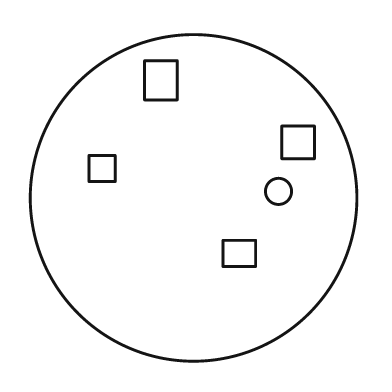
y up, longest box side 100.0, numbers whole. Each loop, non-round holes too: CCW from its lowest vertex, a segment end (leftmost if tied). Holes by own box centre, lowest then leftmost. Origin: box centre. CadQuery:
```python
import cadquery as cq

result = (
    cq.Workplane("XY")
    .moveTo(0.0, 0.0)
    .circle(50.0)
    .moveTo(9.0, -21.0)
    .lineTo(19.0, -21.0)
    .lineTo(19.0, -13.0)
    .lineTo(9.0, -13.0)
    .close()
    .moveTo(26.0, 2.0)
    .circle(4.0)
    .moveTo(-32.0, 5.0)
    .lineTo(-24.0, 5.0)
    .lineTo(-24.0, 13.0)
    .lineTo(-32.0, 13.0)
    .close()
    .moveTo(27.0, 12.0)
    .lineTo(37.0, 12.0)
    .lineTo(37.0, 22.0)
    .lineTo(27.0, 22.0)
    .close()
    .moveTo(-15.0, 30.0)
    .lineTo(-5.0, 30.0)
    .lineTo(-5.0, 42.0)
    .lineTo(-15.0, 42.0)
    .close()
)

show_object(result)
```